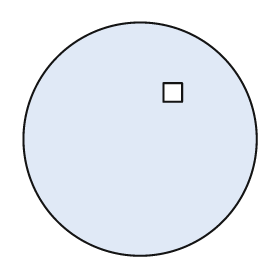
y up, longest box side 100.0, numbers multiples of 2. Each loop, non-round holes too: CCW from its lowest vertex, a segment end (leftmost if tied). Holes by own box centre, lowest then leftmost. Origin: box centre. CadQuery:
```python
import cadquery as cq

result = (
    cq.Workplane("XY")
    .moveTo(0.0, 0.0)
    .circle(50.0)
    .moveTo(10.0, 16.0)
    .lineTo(18.0, 16.0)
    .lineTo(18.0, 24.0)
    .lineTo(10.0, 24.0)
    .close()
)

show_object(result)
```